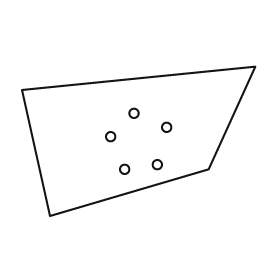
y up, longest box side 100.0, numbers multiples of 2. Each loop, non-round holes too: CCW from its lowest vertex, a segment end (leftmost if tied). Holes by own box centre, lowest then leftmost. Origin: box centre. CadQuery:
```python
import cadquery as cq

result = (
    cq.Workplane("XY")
    .moveTo(-38.0, -32.0)
    .lineTo(30.0, -12.0)
    .lineTo(50.0, 32.0)
    .lineTo(-50.0, 22.0)
    .close()
    .moveTo(-6.0, -12.0)
    .circle(2.0)
    .moveTo(8.0, -10.0)
    .circle(2.0)
    .moveTo(-12.0, 2.0)
    .circle(2.0)
    .moveTo(12.0, 6.0)
    .circle(2.0)
    .moveTo(-2.0, 12.0)
    .circle(2.0)
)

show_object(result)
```